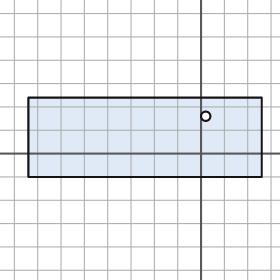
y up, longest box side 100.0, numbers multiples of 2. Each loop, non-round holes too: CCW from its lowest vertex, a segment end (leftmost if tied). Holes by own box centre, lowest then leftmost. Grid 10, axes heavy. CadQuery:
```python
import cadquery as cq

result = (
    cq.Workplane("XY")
    .moveTo(-74.0, -10.0)
    .lineTo(26.0, -10.0)
    .lineTo(26.0, 24.0)
    .lineTo(-74.0, 24.0)
    .close()
    .moveTo(2.0, 16.0)
    .circle(2.0)
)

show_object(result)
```